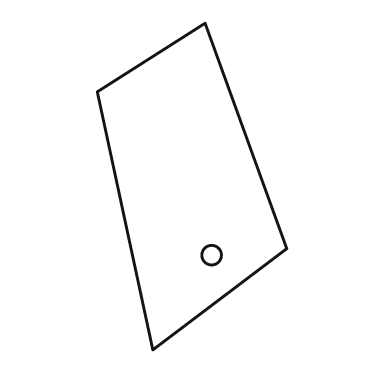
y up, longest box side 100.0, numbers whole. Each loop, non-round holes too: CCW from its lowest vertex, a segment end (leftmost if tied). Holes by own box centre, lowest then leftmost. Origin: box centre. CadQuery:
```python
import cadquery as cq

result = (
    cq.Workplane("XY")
    .moveTo(-12.0, -50.0)
    .lineTo(29.0, -19.0)
    .lineTo(4.0, 50.0)
    .lineTo(-29.0, 29.0)
    .close()
    .moveTo(6.0, -21.0)
    .circle(3.0)
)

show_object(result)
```